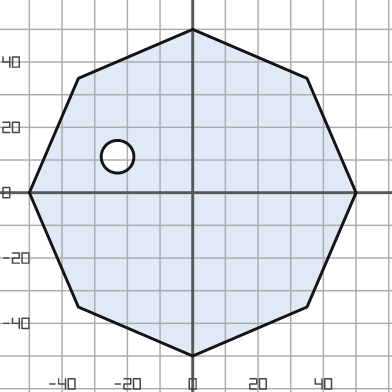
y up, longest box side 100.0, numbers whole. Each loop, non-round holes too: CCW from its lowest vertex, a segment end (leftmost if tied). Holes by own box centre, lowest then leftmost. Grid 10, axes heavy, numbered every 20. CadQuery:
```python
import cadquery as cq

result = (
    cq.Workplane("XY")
    .moveTo(0.0, -50.0)
    .lineTo(35.0, -35.0)
    .lineTo(50.0, 0.0)
    .lineTo(35.0, 35.0)
    .lineTo(0.0, 50.0)
    .lineTo(-35.0, 35.0)
    .lineTo(-50.0, 0.0)
    .lineTo(-35.0, -35.0)
    .close()
    .moveTo(-23.0, 11.0)
    .circle(5.0)
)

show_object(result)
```